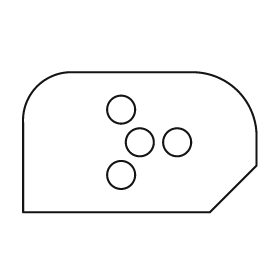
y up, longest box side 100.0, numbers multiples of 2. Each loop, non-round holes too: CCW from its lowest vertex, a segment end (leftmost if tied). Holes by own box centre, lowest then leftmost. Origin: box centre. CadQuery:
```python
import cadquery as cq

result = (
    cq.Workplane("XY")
    .moveTo(-50.0, -30.0)
    .lineTo(30.0, -30.0)
    .lineTo(50.0, -10.0)
    .lineTo(50.0, 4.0)
    .threePointArc((42.0, 22.0), (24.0, 30.0))
    .lineTo(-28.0, 30.0)
    .threePointArc((-44.0, 24.0), (-50.0, 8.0))
    .close()
    .moveTo(-8.0, -14.0)
    .circle(6.0)
    .moveTo(0.0, 0.0)
    .circle(6.0)
    .moveTo(16.0, 0.0)
    .circle(6.0)
    .moveTo(-8.0, 14.0)
    .circle(6.0)
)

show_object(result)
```